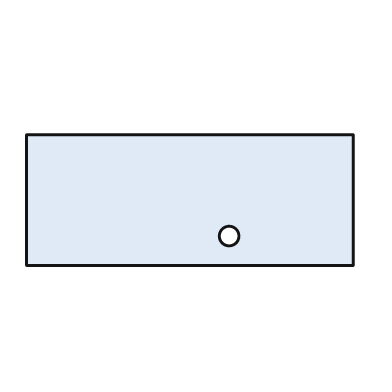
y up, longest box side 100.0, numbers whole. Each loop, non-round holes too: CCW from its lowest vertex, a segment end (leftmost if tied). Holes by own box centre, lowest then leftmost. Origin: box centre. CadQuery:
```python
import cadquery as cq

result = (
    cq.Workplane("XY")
    .moveTo(-50.0, -20.0)
    .lineTo(50.0, -20.0)
    .lineTo(50.0, 20.0)
    .lineTo(-50.0, 20.0)
    .close()
    .moveTo(12.0, -11.0)
    .circle(3.0)
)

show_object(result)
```